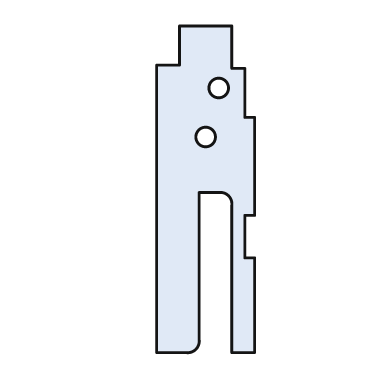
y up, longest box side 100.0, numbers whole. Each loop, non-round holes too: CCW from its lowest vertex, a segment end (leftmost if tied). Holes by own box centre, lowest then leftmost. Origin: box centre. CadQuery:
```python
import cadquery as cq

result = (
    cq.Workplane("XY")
    .moveTo(-15.0, -50.0)
    .lineTo(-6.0, -50.0)
    .threePointArc((-3.0, -49.0), (-2.0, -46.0))
    .lineTo(-2.0, -1.0)
    .lineTo(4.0, -1.0)
    .threePointArc((7.0, -2.0), (8.0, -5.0))
    .lineTo(8.0, -50.0)
    .lineTo(15.0, -50.0)
    .lineTo(15.0, -21.0)
    .lineTo(12.0, -21.0)
    .lineTo(12.0, -8.0)
    .lineTo(15.0, -8.0)
    .lineTo(15.0, 22.0)
    .lineTo(12.0, 22.0)
    .lineTo(12.0, 37.0)
    .lineTo(8.0, 37.0)
    .lineTo(8.0, 50.0)
    .lineTo(-8.0, 50.0)
    .lineTo(-8.0, 38.0)
    .lineTo(-15.0, 38.0)
    .close()
    .moveTo(0.0, 16.0)
    .circle(3.0)
    .moveTo(4.0, 31.0)
    .circle(3.0)
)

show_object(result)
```